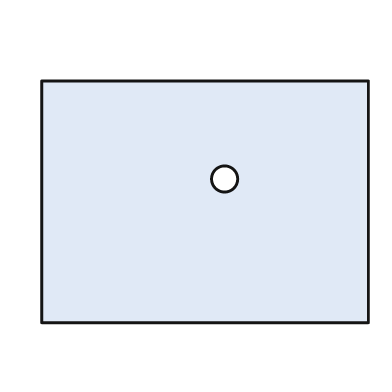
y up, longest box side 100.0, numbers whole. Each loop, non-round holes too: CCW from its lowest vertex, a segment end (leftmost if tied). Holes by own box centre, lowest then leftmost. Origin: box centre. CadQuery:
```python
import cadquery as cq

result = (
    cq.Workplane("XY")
    .moveTo(-50.0, -37.0)
    .lineTo(50.0, -37.0)
    .lineTo(50.0, 37.0)
    .lineTo(-50.0, 37.0)
    .close()
    .moveTo(6.0, 7.0)
    .circle(4.0)
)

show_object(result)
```